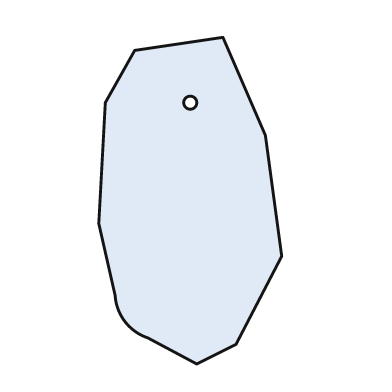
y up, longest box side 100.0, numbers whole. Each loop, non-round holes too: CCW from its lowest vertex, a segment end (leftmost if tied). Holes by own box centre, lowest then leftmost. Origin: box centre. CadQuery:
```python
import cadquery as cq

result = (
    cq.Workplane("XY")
    .moveTo(2.0, -50.0)
    .lineTo(14.0, -44.0)
    .lineTo(28.0, -17.0)
    .lineTo(23.0, 20.0)
    .lineTo(10.0, 50.0)
    .lineTo(-17.0, 46.0)
    .lineTo(-26.0, 30.0)
    .lineTo(-28.0, -7.0)
    .lineTo(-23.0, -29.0)
    .threePointArc((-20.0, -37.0), (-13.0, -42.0))
    .close()
    .moveTo(0.0, 30.0)
    .circle(2.0)
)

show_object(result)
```